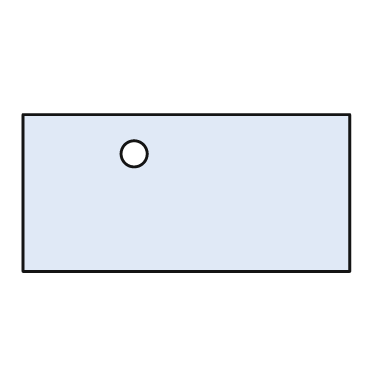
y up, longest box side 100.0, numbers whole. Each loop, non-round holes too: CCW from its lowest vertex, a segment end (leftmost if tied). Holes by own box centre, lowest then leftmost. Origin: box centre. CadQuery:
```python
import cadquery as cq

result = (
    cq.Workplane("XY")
    .moveTo(-50.0, -24.0)
    .lineTo(50.0, -24.0)
    .lineTo(50.0, 24.0)
    .lineTo(-50.0, 24.0)
    .close()
    .moveTo(-16.0, 12.0)
    .circle(4.0)
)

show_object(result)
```